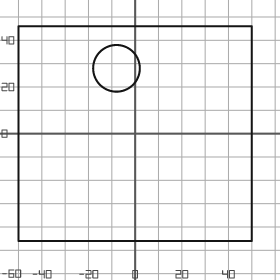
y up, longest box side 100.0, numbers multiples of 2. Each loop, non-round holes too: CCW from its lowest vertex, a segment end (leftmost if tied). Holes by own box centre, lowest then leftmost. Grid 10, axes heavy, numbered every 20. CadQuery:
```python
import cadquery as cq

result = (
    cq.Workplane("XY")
    .moveTo(-50.0, -46.0)
    .lineTo(50.0, -46.0)
    .lineTo(50.0, 46.0)
    .lineTo(-50.0, 46.0)
    .close()
    .moveTo(-8.0, 28.0)
    .circle(10.0)
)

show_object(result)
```